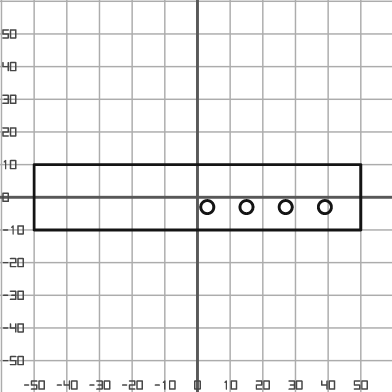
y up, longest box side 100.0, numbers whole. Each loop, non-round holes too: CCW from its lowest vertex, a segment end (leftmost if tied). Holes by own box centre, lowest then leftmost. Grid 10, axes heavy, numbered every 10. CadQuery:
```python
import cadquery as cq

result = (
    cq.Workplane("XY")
    .moveTo(-50.0, -10.0)
    .lineTo(50.0, -10.0)
    .lineTo(50.0, 10.0)
    .lineTo(-50.0, 10.0)
    .close()
    .moveTo(3.0, -3.0)
    .circle(2.0)
    .moveTo(15.0, -3.0)
    .circle(2.0)
    .moveTo(27.0, -3.0)
    .circle(2.0)
    .moveTo(39.0, -3.0)
    .circle(2.0)
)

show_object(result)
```